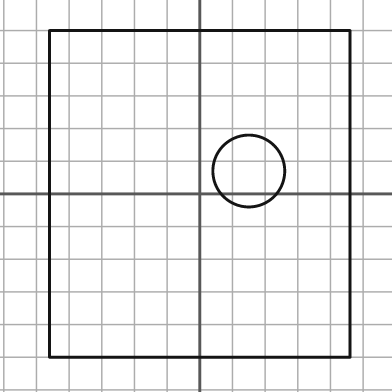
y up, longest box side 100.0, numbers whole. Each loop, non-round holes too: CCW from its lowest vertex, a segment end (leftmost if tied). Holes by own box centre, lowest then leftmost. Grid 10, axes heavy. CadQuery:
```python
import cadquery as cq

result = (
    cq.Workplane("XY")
    .moveTo(-46.0, -50.0)
    .lineTo(46.0, -50.0)
    .lineTo(46.0, 50.0)
    .lineTo(-46.0, 50.0)
    .close()
    .moveTo(15.0, 7.0)
    .circle(11.0)
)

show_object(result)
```